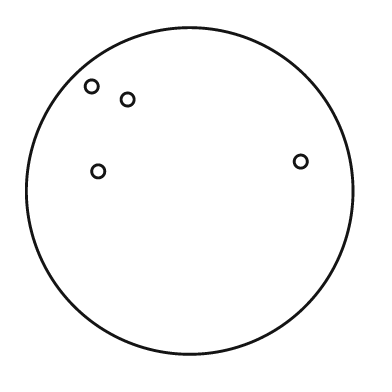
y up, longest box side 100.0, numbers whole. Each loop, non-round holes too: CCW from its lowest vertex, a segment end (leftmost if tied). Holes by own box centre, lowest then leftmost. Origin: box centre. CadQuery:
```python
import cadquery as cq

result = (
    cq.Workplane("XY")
    .moveTo(0.0, 0.0)
    .circle(50.0)
    .moveTo(-28.0, 6.0)
    .circle(2.0)
    .moveTo(34.0, 9.0)
    .circle(2.0)
    .moveTo(-19.0, 28.0)
    .circle(2.0)
    .moveTo(-30.0, 32.0)
    .circle(2.0)
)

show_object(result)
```